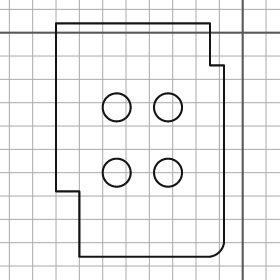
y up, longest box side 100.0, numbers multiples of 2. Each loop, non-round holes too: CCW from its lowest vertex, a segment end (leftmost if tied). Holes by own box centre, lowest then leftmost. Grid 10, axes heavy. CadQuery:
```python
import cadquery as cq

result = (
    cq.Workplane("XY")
    .moveTo(-70.0, -96.0)
    .lineTo(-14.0, -96.0)
    .threePointArc((-10.0, -94.0), (-8.0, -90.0))
    .lineTo(-8.0, -14.0)
    .lineTo(-14.0, -14.0)
    .lineTo(-14.0, 4.0)
    .lineTo(-80.0, 4.0)
    .lineTo(-80.0, -68.0)
    .lineTo(-70.0, -68.0)
    .close()
    .moveTo(-54.0, -60.0)
    .circle(6.0)
    .moveTo(-32.0, -60.0)
    .circle(6.0)
    .moveTo(-54.0, -32.0)
    .circle(6.0)
    .moveTo(-32.0, -32.0)
    .circle(6.0)
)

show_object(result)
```